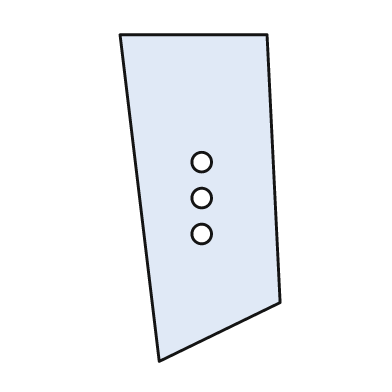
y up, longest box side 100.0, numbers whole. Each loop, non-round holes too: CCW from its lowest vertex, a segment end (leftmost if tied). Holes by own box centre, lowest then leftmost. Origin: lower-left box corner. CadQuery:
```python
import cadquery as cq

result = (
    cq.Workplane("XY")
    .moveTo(12.0, 0.0)
    .lineTo(49.0, 18.0)
    .lineTo(45.0, 100.0)
    .lineTo(0.0, 100.0)
    .close()
    .moveTo(25.0, 39.0)
    .circle(3.0)
    .moveTo(25.0, 50.0)
    .circle(3.0)
    .moveTo(25.0, 61.0)
    .circle(3.0)
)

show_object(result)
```